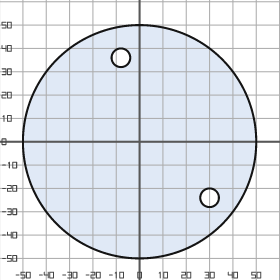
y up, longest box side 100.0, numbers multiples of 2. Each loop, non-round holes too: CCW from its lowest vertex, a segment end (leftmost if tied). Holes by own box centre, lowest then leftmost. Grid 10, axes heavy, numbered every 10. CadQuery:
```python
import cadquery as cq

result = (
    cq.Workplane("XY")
    .moveTo(0.0, 0.0)
    .circle(50.0)
    .moveTo(30.0, -24.0)
    .circle(4.0)
    .moveTo(-8.0, 36.0)
    .circle(4.0)
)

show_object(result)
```